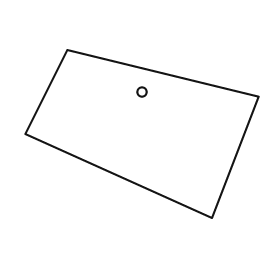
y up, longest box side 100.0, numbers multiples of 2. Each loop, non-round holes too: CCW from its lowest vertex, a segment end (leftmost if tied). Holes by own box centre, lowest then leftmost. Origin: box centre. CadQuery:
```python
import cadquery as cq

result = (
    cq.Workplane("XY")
    .moveTo(30.0, -36.0)
    .lineTo(50.0, 16.0)
    .lineTo(-32.0, 36.0)
    .lineTo(-50.0, 0.0)
    .close()
    .moveTo(0.0, 18.0)
    .circle(2.0)
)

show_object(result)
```